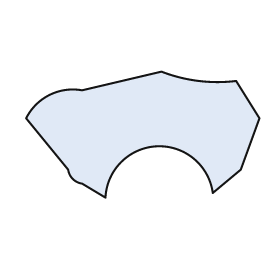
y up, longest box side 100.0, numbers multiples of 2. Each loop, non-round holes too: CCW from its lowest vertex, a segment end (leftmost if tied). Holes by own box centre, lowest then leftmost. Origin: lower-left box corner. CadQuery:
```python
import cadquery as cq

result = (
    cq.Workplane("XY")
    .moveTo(34.0, 0.0)
    .threePointArc((56.0, 22.0), (80.0, 2.0))
    .lineTo(92.0, 12.0)
    .lineTo(100.0, 34.0)
    .lineTo(90.0, 50.0)
    .threePointArc((74.0, 50.0), (58.0, 54.0))
    .lineTo(24.0, 46.0)
    .threePointArc((10.0, 44.0), (0.0, 34.0))
    .lineTo(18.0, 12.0)
    .threePointArc((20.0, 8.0), (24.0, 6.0))
    .close()
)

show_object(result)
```